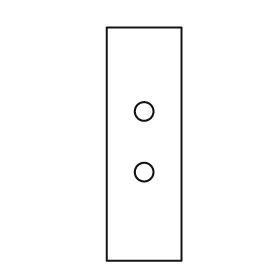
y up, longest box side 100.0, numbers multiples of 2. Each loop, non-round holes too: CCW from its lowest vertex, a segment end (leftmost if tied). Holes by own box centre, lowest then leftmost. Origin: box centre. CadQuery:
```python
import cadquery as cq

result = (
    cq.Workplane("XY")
    .moveTo(-16.0, -50.0)
    .lineTo(16.0, -50.0)
    .lineTo(16.0, 50.0)
    .lineTo(-16.0, 50.0)
    .close()
    .moveTo(0.0, -12.0)
    .circle(4.0)
    .moveTo(0.0, 14.0)
    .circle(4.0)
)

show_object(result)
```